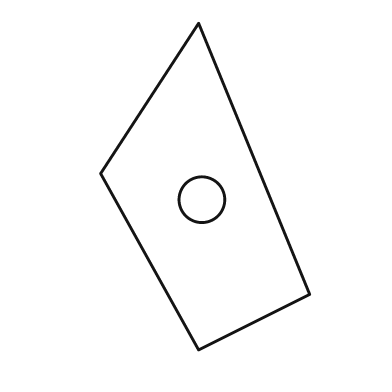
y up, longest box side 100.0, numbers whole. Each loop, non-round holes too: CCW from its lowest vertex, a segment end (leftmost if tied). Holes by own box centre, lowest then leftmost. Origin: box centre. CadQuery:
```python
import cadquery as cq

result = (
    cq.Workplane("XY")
    .moveTo(-2.0, -50.0)
    .lineTo(32.0, -33.0)
    .lineTo(-2.0, 50.0)
    .lineTo(-32.0, 4.0)
    .close()
    .moveTo(-1.0, -4.0)
    .circle(7.0)
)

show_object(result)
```